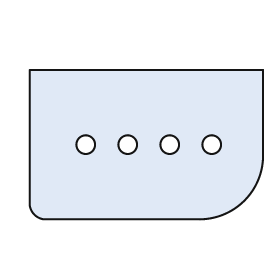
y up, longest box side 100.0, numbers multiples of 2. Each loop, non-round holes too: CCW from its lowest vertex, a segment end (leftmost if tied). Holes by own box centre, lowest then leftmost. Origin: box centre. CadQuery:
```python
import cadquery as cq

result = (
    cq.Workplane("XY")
    .moveTo(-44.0, -32.0)
    .lineTo(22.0, -32.0)
    .threePointArc((42.0, -24.0), (50.0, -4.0))
    .lineTo(50.0, 32.0)
    .lineTo(-50.0, 32.0)
    .lineTo(-50.0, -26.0)
    .threePointArc((-48.0, -30.0), (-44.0, -32.0))
    .close()
    .moveTo(-26.0, 0.0)
    .circle(4.0)
    .moveTo(-8.0, 0.0)
    .circle(4.0)
    .moveTo(10.0, 0.0)
    .circle(4.0)
    .moveTo(28.0, 0.0)
    .circle(4.0)
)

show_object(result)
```